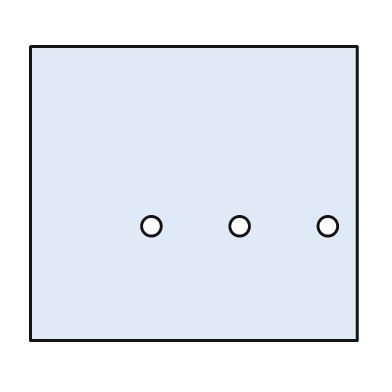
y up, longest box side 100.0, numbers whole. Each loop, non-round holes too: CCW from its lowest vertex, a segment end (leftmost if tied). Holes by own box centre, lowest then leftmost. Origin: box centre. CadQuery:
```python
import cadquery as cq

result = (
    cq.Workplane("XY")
    .moveTo(-50.0, -45.0)
    .lineTo(50.0, -45.0)
    .lineTo(50.0, 45.0)
    .lineTo(-50.0, 45.0)
    .close()
    .moveTo(-13.0, -10.0)
    .circle(3.0)
    .moveTo(14.0, -10.0)
    .circle(3.0)
    .moveTo(41.0, -10.0)
    .circle(3.0)
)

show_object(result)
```